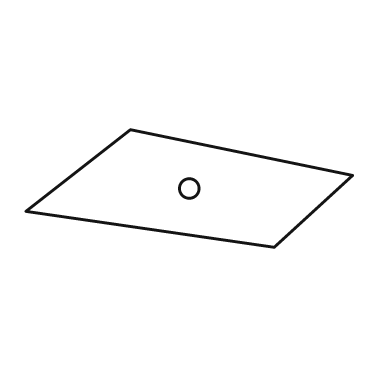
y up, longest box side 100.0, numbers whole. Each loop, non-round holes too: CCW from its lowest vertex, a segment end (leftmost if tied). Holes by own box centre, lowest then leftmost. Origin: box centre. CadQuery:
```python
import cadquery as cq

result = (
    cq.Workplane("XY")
    .moveTo(26.0, -18.0)
    .lineTo(50.0, 4.0)
    .lineTo(-18.0, 18.0)
    .lineTo(-50.0, -7.0)
    .close()
    .moveTo(0.0, 0.0)
    .circle(3.0)
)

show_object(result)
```